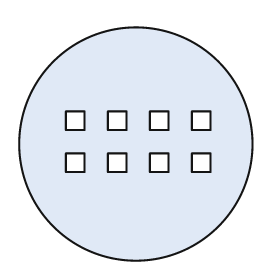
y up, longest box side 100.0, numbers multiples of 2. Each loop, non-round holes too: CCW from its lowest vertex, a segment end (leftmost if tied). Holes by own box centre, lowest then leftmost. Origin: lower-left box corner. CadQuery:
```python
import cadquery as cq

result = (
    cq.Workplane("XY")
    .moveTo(50.0, 50.0)
    .circle(50.0)
    .moveTo(20.0, 38.0)
    .lineTo(28.0, 38.0)
    .lineTo(28.0, 46.0)
    .lineTo(20.0, 46.0)
    .close()
    .moveTo(38.0, 38.0)
    .lineTo(46.0, 38.0)
    .lineTo(46.0, 46.0)
    .lineTo(38.0, 46.0)
    .close()
    .moveTo(56.0, 38.0)
    .lineTo(64.0, 38.0)
    .lineTo(64.0, 46.0)
    .lineTo(56.0, 46.0)
    .close()
    .moveTo(74.0, 38.0)
    .lineTo(82.0, 38.0)
    .lineTo(82.0, 46.0)
    .lineTo(74.0, 46.0)
    .close()
    .moveTo(20.0, 56.0)
    .lineTo(28.0, 56.0)
    .lineTo(28.0, 64.0)
    .lineTo(20.0, 64.0)
    .close()
    .moveTo(38.0, 56.0)
    .lineTo(46.0, 56.0)
    .lineTo(46.0, 64.0)
    .lineTo(38.0, 64.0)
    .close()
    .moveTo(56.0, 56.0)
    .lineTo(64.0, 56.0)
    .lineTo(64.0, 64.0)
    .lineTo(56.0, 64.0)
    .close()
    .moveTo(74.0, 56.0)
    .lineTo(82.0, 56.0)
    .lineTo(82.0, 64.0)
    .lineTo(74.0, 64.0)
    .close()
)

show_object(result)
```